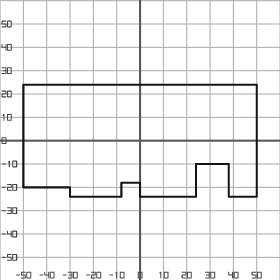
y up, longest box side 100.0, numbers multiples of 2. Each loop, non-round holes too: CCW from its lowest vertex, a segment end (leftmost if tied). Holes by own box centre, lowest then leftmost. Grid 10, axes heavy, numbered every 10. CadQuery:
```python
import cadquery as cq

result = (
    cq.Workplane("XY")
    .moveTo(-30.0, -24.0)
    .lineTo(-8.0, -24.0)
    .lineTo(-8.0, -18.0)
    .lineTo(0.0, -18.0)
    .lineTo(0.0, -24.0)
    .lineTo(24.0, -24.0)
    .lineTo(24.0, -10.0)
    .lineTo(38.0, -10.0)
    .lineTo(38.0, -24.0)
    .lineTo(50.0, -24.0)
    .lineTo(50.0, 24.0)
    .lineTo(-50.0, 24.0)
    .lineTo(-50.0, -20.0)
    .lineTo(-30.0, -20.0)
    .close()
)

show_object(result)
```